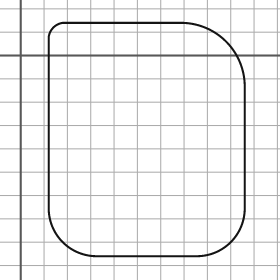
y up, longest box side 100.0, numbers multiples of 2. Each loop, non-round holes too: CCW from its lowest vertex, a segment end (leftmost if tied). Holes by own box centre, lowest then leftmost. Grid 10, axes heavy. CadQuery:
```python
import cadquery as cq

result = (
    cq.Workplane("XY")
    .moveTo(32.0, -86.0)
    .lineTo(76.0, -86.0)
    .threePointArc((90.0, -80.0), (96.0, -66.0))
    .lineTo(96.0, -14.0)
    .threePointArc((88.0, 6.0), (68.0, 14.0))
    .lineTo(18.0, 14.0)
    .threePointArc((14.0, 12.0), (12.0, 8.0))
    .lineTo(12.0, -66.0)
    .threePointArc((18.0, -80.0), (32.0, -86.0))
    .close()
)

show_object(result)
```